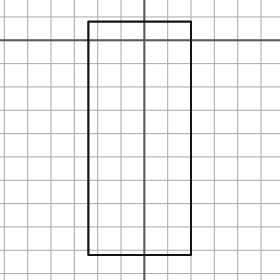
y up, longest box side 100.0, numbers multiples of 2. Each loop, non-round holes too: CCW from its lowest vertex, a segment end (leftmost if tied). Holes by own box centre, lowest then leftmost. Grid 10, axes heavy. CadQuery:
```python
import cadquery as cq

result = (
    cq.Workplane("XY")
    .moveTo(-24.0, -92.0)
    .lineTo(20.0, -92.0)
    .lineTo(20.0, 8.0)
    .lineTo(-24.0, 8.0)
    .close()
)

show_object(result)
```